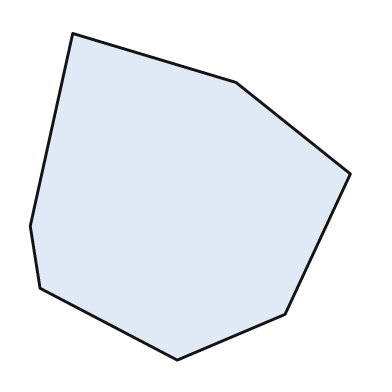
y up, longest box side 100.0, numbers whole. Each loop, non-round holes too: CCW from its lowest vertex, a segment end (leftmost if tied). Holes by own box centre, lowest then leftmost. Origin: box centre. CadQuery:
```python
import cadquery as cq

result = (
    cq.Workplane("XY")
    .moveTo(-4.0, -50.0)
    .lineTo(29.0, -36.0)
    .lineTo(49.0, 7.0)
    .lineTo(14.0, 35.0)
    .lineTo(-36.0, 50.0)
    .lineTo(-49.0, -9.0)
    .lineTo(-46.0, -28.0)
    .close()
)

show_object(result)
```